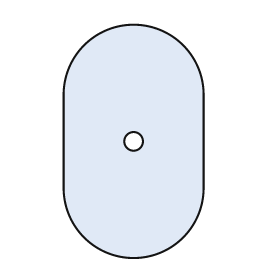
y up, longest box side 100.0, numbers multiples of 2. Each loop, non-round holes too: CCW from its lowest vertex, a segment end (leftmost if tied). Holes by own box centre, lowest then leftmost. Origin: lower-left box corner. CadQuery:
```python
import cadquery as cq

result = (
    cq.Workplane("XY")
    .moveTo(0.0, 30.0)
    .threePointArc((30.0, 0.0), (60.0, 30.0))
    .lineTo(60.0, 70.0)
    .threePointArc((30.0, 100.0), (0.0, 70.0))
    .close()
    .moveTo(30.0, 50.0)
    .circle(4.0)
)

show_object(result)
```